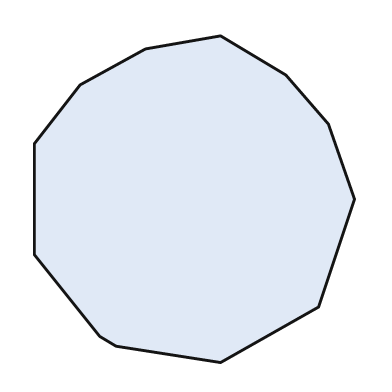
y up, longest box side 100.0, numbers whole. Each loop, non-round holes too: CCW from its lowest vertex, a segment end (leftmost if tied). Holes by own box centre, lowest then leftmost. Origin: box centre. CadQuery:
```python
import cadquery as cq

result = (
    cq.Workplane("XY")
    .moveTo(8.0, -50.0)
    .lineTo(38.0, -33.0)
    .lineTo(49.0, 0.0)
    .lineTo(41.0, 23.0)
    .lineTo(28.0, 38.0)
    .lineTo(8.0, 50.0)
    .lineTo(-15.0, 46.0)
    .lineTo(-35.0, 35.0)
    .lineTo(-49.0, 17.0)
    .lineTo(-49.0, -17.0)
    .lineTo(-29.0, -42.0)
    .lineTo(-24.0, -45.0)
    .close()
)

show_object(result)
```